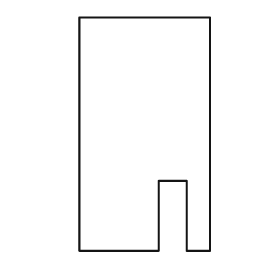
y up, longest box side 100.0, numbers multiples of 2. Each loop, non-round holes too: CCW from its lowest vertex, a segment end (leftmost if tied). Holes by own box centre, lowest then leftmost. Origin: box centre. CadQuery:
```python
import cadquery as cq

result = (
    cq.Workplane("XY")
    .moveTo(-28.0, -50.0)
    .lineTo(6.0, -50.0)
    .lineTo(6.0, -20.0)
    .lineTo(18.0, -20.0)
    .lineTo(18.0, -50.0)
    .lineTo(28.0, -50.0)
    .lineTo(28.0, 50.0)
    .lineTo(-28.0, 50.0)
    .close()
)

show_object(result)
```